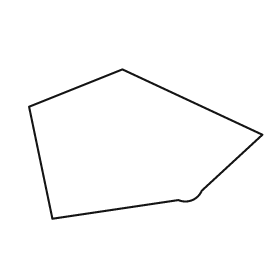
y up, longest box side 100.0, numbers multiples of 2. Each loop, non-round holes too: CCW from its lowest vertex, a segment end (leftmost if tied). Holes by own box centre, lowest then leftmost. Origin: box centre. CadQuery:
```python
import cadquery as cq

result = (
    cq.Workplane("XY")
    .moveTo(-40.0, -32.0)
    .lineTo(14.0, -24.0)
    .threePointArc((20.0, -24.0), (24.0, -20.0))
    .lineTo(50.0, 4.0)
    .lineTo(-10.0, 32.0)
    .lineTo(-50.0, 16.0)
    .close()
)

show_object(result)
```